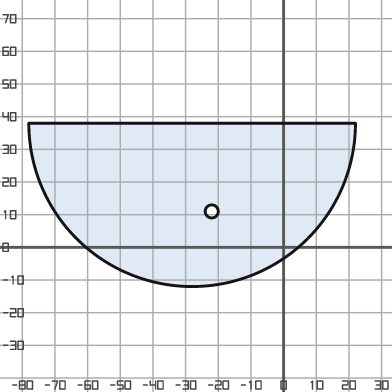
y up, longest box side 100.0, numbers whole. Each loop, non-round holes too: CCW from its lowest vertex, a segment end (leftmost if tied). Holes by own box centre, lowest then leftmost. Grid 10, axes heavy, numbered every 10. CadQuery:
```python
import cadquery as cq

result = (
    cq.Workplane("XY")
    .moveTo(-78.0, 38.0)
    .threePointArc((-28.0, -12.0), (22.0, 38.0))
    .close()
    .moveTo(-22.0, 11.0)
    .circle(2.0)
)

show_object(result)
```